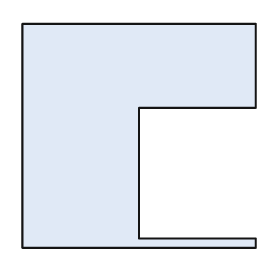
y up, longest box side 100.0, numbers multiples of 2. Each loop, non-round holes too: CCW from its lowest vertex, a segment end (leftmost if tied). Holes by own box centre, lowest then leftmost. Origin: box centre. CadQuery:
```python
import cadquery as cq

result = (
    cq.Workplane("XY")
    .moveTo(-50.0, -48.0)
    .lineTo(50.0, -48.0)
    .lineTo(50.0, -44.0)
    .lineTo(0.0, -44.0)
    .lineTo(0.0, 12.0)
    .lineTo(50.0, 12.0)
    .lineTo(50.0, 48.0)
    .lineTo(-50.0, 48.0)
    .close()
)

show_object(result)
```